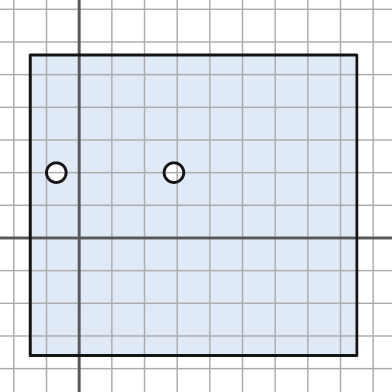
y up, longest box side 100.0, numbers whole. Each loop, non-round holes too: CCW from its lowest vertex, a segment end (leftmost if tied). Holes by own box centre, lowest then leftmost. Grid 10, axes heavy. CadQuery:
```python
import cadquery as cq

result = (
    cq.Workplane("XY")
    .moveTo(-15.0, -36.0)
    .lineTo(85.0, -36.0)
    .lineTo(85.0, 56.0)
    .lineTo(-15.0, 56.0)
    .close()
    .moveTo(-7.0, 20.0)
    .circle(3.0)
    .moveTo(29.0, 20.0)
    .circle(3.0)
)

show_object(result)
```